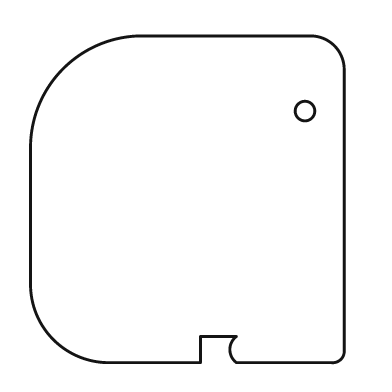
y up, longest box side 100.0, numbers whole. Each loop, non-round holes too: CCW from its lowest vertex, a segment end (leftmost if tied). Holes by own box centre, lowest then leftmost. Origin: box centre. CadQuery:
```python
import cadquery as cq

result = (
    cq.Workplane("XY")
    .moveTo(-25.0, -50.0)
    .lineTo(4.0, -50.0)
    .lineTo(4.0, -42.0)
    .lineTo(15.0, -42.0)
    .threePointArc((13.0, -46.0), (15.0, -50.0))
    .lineTo(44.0, -50.0)
    .threePointArc((47.0, -49.0), (48.0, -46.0))
    .lineTo(48.0, 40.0)
    .threePointArc((45.0, 47.0), (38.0, 50.0))
    .lineTo(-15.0, 50.0)
    .threePointArc((-38.0, 40.0), (-48.0, 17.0))
    .lineTo(-48.0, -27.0)
    .threePointArc((-41.0, -43.0), (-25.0, -50.0))
    .close()
    .moveTo(36.0, 27.0)
    .circle(3.0)
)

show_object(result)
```